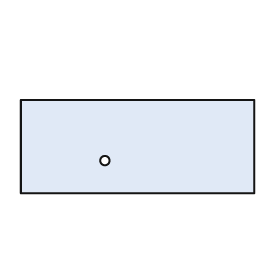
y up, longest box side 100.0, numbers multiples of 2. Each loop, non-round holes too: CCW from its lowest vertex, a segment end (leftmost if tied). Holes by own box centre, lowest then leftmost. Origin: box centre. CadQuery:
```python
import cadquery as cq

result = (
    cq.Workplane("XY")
    .moveTo(-50.0, -20.0)
    .lineTo(50.0, -20.0)
    .lineTo(50.0, 20.0)
    .lineTo(-50.0, 20.0)
    .close()
    .moveTo(-14.0, -6.0)
    .circle(2.0)
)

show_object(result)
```